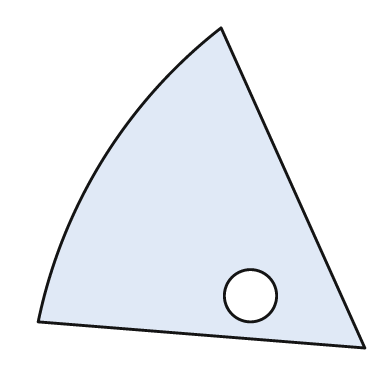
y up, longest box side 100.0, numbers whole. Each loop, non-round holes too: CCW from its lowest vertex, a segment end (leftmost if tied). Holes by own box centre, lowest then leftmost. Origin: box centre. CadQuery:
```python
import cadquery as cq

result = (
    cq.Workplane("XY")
    .moveTo(50.0, -49.0)
    .lineTo(6.0, 49.0)
    .threePointArc((-30.0, 9.0), (-50.0, -41.0))
    .close()
    .moveTo(15.0, -33.0)
    .circle(8.0)
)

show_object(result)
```